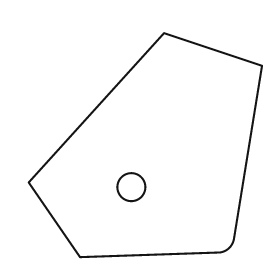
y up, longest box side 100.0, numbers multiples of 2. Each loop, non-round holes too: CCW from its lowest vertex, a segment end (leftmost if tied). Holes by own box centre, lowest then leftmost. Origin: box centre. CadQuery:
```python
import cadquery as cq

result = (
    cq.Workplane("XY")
    .moveTo(-28.0, -48.0)
    .lineTo(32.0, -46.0)
    .threePointArc((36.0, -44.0), (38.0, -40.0))
    .lineTo(50.0, 34.0)
    .lineTo(8.0, 48.0)
    .lineTo(-50.0, -16.0)
    .close()
    .moveTo(-6.0, -18.0)
    .circle(6.0)
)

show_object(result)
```